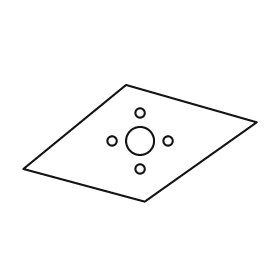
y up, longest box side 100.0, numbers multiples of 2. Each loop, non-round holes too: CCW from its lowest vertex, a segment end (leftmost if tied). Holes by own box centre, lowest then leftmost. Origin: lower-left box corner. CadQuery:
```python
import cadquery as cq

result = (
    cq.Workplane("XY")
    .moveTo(52.0, 0.0)
    .lineTo(100.0, 34.0)
    .lineTo(44.0, 50.0)
    .lineTo(0.0, 14.0)
    .close()
    .moveTo(50.0, 14.0)
    .circle(2.0)
    .moveTo(38.0, 26.0)
    .circle(2.0)
    .moveTo(50.0, 26.0)
    .circle(6.0)
    .moveTo(62.0, 26.0)
    .circle(2.0)
    .moveTo(50.0, 38.0)
    .circle(2.0)
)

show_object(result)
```